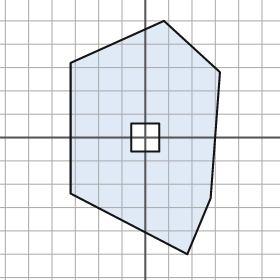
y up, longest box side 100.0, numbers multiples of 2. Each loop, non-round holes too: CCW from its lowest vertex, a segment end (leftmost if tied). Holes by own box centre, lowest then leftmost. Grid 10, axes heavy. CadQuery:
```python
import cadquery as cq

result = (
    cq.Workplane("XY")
    .moveTo(18.0, -50.0)
    .lineTo(28.0, -26.0)
    .lineTo(32.0, 28.0)
    .lineTo(8.0, 50.0)
    .lineTo(-32.0, 32.0)
    .lineTo(-32.0, -24.0)
    .close()
    .moveTo(-6.0, -6.0)
    .lineTo(6.0, -6.0)
    .lineTo(6.0, 6.0)
    .lineTo(-6.0, 6.0)
    .close()
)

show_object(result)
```